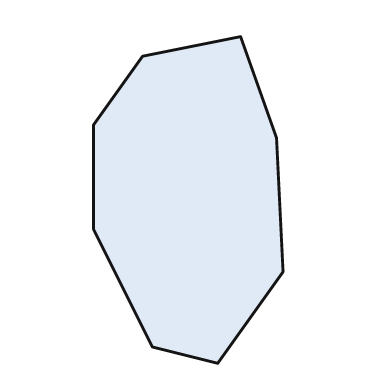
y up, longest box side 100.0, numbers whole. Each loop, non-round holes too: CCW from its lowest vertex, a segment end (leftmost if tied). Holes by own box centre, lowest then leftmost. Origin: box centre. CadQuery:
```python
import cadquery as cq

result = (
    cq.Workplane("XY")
    .moveTo(9.0, -50.0)
    .lineTo(29.0, -22.0)
    .lineTo(27.0, 19.0)
    .lineTo(16.0, 50.0)
    .lineTo(-14.0, 44.0)
    .lineTo(-29.0, 23.0)
    .lineTo(-29.0, -9.0)
    .lineTo(-11.0, -45.0)
    .close()
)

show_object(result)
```